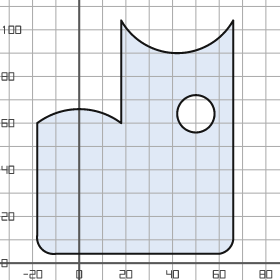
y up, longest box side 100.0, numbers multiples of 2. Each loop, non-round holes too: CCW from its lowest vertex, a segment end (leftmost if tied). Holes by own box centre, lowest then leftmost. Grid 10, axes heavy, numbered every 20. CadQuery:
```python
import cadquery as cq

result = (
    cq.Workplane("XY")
    .moveTo(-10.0, 4.0)
    .lineTo(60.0, 4.0)
    .threePointArc((64.0, 6.0), (66.0, 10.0))
    .lineTo(66.0, 104.0)
    .threePointArc((42.0, 90.0), (18.0, 104.0))
    .lineTo(18.0, 60.0)
    .threePointArc((0.0, 66.0), (-18.0, 60.0))
    .lineTo(-18.0, 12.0)
    .threePointArc((-16.0, 6.0), (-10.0, 4.0))
    .close()
    .moveTo(50.0, 64.0)
    .circle(8.0)
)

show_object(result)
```